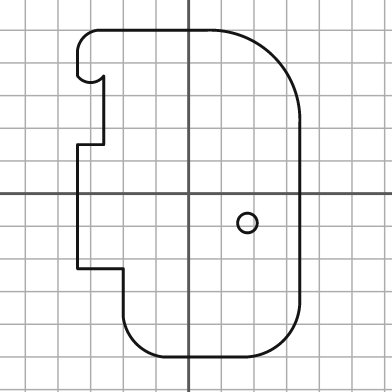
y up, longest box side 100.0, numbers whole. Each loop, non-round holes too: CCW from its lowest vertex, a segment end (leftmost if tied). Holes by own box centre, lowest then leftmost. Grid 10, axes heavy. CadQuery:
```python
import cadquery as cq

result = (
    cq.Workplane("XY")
    .moveTo(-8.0, -50.0)
    .lineTo(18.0, -50.0)
    .threePointArc((29.0, -45.0), (34.0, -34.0))
    .lineTo(34.0, 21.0)
    .threePointArc((26.0, 42.0), (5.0, 50.0))
    .lineTo(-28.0, 50.0)
    .threePointArc((-32.0, 48.0), (-34.0, 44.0))
    .lineTo(-34.0, 36.0)
    .threePointArc((-30.0, 34.0), (-26.0, 36.0))
    .lineTo(-26.0, 15.0)
    .lineTo(-34.0, 15.0)
    .lineTo(-34.0, -23.0)
    .lineTo(-20.0, -23.0)
    .lineTo(-20.0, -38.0)
    .threePointArc((-16.0, -46.0), (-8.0, -50.0))
    .close()
    .moveTo(18.0, -9.0)
    .circle(3.0)
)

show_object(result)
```